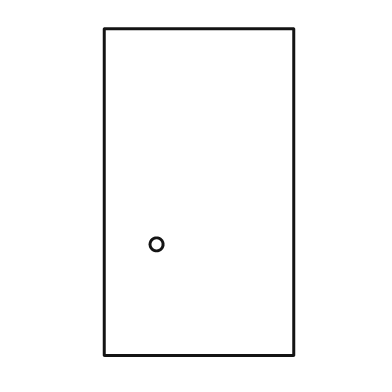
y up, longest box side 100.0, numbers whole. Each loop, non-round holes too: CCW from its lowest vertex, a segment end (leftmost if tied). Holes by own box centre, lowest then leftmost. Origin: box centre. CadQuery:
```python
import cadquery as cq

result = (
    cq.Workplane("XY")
    .moveTo(-29.0, -50.0)
    .lineTo(29.0, -50.0)
    .lineTo(29.0, 50.0)
    .lineTo(-29.0, 50.0)
    .close()
    .moveTo(-13.0, -16.0)
    .circle(2.0)
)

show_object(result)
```